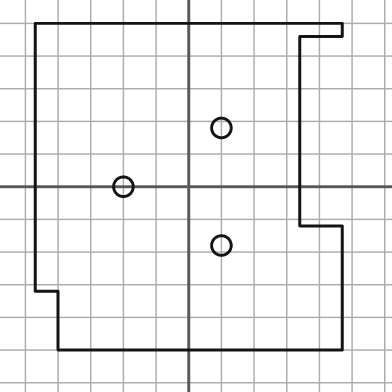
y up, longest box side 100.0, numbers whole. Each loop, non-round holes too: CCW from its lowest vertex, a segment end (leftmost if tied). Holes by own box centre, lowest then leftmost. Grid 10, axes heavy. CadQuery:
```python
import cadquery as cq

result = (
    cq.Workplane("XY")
    .moveTo(-40.0, -50.0)
    .lineTo(47.0, -50.0)
    .lineTo(47.0, -12.0)
    .lineTo(34.0, -12.0)
    .lineTo(34.0, 46.0)
    .lineTo(47.0, 46.0)
    .lineTo(47.0, 50.0)
    .lineTo(-47.0, 50.0)
    .lineTo(-47.0, -32.0)
    .lineTo(-40.0, -32.0)
    .close()
    .moveTo(10.0, -18.0)
    .circle(3.0)
    .moveTo(-20.0, 0.0)
    .circle(3.0)
    .moveTo(10.0, 18.0)
    .circle(3.0)
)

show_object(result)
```